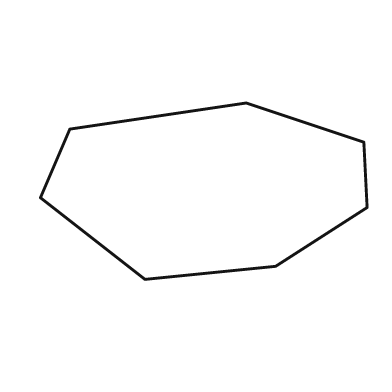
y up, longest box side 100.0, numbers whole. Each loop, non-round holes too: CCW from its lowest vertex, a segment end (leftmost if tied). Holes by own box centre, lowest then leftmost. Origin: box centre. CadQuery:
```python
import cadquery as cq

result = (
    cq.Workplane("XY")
    .moveTo(-18.0, -27.0)
    .lineTo(22.0, -23.0)
    .lineTo(50.0, -5.0)
    .lineTo(49.0, 15.0)
    .lineTo(13.0, 27.0)
    .lineTo(-41.0, 19.0)
    .lineTo(-50.0, -2.0)
    .close()
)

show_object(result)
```